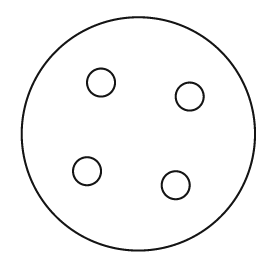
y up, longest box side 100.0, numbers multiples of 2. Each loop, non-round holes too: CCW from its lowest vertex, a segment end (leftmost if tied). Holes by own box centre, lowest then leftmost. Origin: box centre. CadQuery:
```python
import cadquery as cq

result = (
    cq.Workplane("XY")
    .moveTo(0.0, 0.0)
    .circle(50.0)
    .moveTo(16.0, -22.0)
    .circle(6.0)
    .moveTo(-22.0, -16.0)
    .circle(6.0)
    .moveTo(22.0, 16.0)
    .circle(6.0)
    .moveTo(-16.0, 22.0)
    .circle(6.0)
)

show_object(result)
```